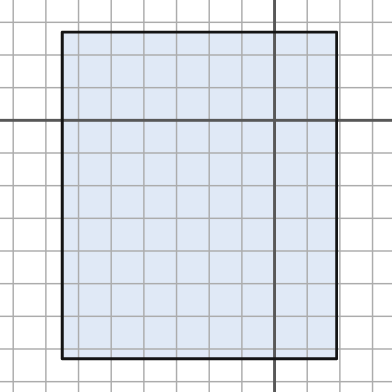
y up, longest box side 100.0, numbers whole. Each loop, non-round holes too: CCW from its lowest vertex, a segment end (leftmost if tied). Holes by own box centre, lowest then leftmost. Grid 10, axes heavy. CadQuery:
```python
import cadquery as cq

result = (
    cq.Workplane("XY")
    .moveTo(-65.0, -73.0)
    .lineTo(19.0, -73.0)
    .lineTo(19.0, 27.0)
    .lineTo(-65.0, 27.0)
    .close()
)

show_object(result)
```